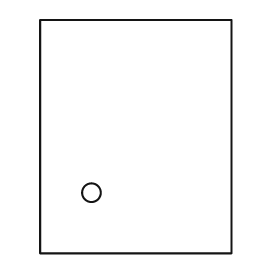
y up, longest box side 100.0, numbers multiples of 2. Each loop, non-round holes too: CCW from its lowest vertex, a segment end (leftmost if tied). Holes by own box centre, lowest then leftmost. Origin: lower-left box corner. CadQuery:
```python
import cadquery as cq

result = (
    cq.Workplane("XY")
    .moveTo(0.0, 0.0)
    .lineTo(82.0, 0.0)
    .lineTo(82.0, 100.0)
    .lineTo(0.0, 100.0)
    .close()
    .moveTo(22.0, 26.0)
    .circle(4.0)
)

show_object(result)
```